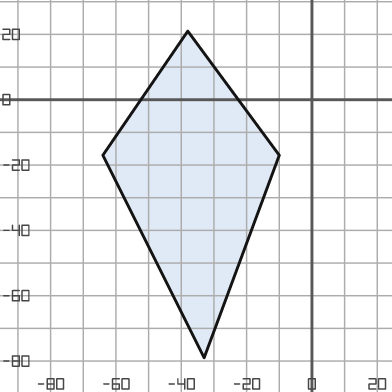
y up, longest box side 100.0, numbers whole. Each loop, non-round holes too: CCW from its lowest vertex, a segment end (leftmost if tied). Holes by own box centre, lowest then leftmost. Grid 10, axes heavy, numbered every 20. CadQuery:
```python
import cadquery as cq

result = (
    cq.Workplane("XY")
    .moveTo(-33.0, -79.0)
    .lineTo(-10.0, -17.0)
    .lineTo(-38.0, 21.0)
    .lineTo(-64.0, -17.0)
    .close()
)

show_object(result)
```